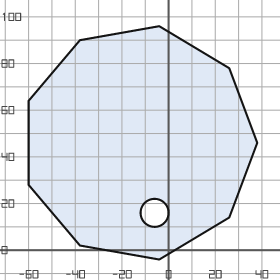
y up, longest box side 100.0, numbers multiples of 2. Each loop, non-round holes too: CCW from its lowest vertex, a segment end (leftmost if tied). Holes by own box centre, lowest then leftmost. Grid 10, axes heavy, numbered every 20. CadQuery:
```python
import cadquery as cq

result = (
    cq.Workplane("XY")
    .moveTo(-4.0, -4.0)
    .lineTo(26.0, 14.0)
    .lineTo(38.0, 46.0)
    .lineTo(26.0, 78.0)
    .lineTo(-4.0, 96.0)
    .lineTo(-38.0, 90.0)
    .lineTo(-60.0, 64.0)
    .lineTo(-60.0, 28.0)
    .lineTo(-38.0, 2.0)
    .close()
    .moveTo(-6.0, 16.0)
    .circle(6.0)
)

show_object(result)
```